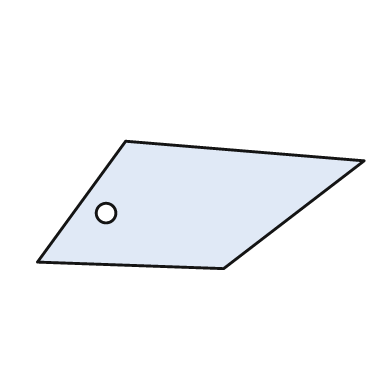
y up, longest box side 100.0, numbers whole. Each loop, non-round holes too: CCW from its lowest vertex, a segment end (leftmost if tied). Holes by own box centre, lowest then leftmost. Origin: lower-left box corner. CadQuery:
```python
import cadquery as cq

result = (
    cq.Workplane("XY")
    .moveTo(57.0, 0.0)
    .lineTo(100.0, 33.0)
    .lineTo(27.0, 39.0)
    .lineTo(0.0, 2.0)
    .close()
    .moveTo(21.0, 17.0)
    .circle(3.0)
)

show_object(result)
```